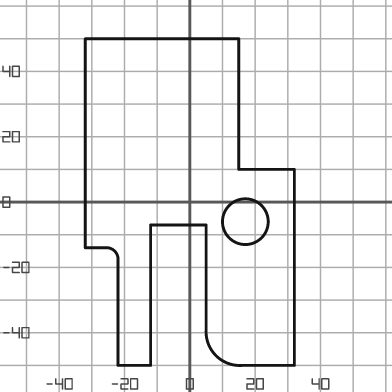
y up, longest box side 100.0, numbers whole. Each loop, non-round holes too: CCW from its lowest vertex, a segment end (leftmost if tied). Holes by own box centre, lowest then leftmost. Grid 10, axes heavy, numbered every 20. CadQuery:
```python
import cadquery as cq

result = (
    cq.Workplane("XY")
    .moveTo(-22.0, -50.0)
    .lineTo(-12.0, -50.0)
    .lineTo(-12.0, -7.0)
    .lineTo(5.0, -7.0)
    .lineTo(5.0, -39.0)
    .threePointArc((8.0, -47.0), (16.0, -50.0))
    .lineTo(32.0, -50.0)
    .lineTo(32.0, 10.0)
    .lineTo(15.0, 10.0)
    .lineTo(15.0, 50.0)
    .lineTo(-32.0, 50.0)
    .lineTo(-32.0, -14.0)
    .lineTo(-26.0, -14.0)
    .threePointArc((-23.0, -15.0), (-22.0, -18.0))
    .close()
    .moveTo(17.0, -6.0)
    .circle(7.0)
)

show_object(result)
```